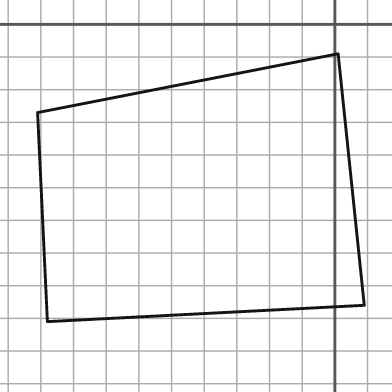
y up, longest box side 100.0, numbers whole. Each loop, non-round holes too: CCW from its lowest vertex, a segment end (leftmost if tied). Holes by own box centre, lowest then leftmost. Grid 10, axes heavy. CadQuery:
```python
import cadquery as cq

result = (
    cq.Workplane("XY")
    .moveTo(-88.0, -91.0)
    .lineTo(9.0, -86.0)
    .lineTo(1.0, -9.0)
    .lineTo(-91.0, -27.0)
    .close()
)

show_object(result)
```